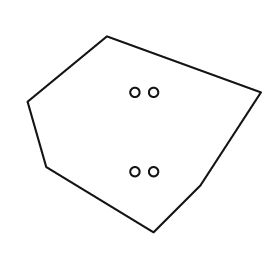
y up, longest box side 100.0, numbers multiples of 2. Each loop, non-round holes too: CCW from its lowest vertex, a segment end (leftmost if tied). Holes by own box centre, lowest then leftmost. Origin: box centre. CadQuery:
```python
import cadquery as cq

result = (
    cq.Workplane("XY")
    .moveTo(4.0, -42.0)
    .lineTo(24.0, -22.0)
    .lineTo(50.0, 18.0)
    .lineTo(-16.0, 42.0)
    .lineTo(-50.0, 14.0)
    .lineTo(-42.0, -14.0)
    .close()
    .moveTo(-4.0, -16.0)
    .circle(2.0)
    .moveTo(4.0, -16.0)
    .circle(2.0)
    .moveTo(-4.0, 18.0)
    .circle(2.0)
    .moveTo(4.0, 18.0)
    .circle(2.0)
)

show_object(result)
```